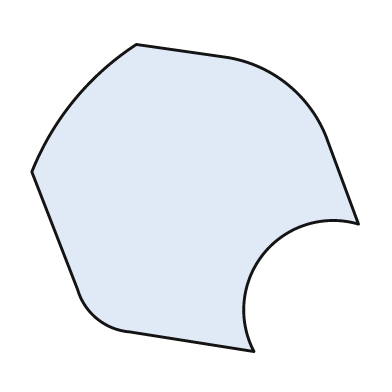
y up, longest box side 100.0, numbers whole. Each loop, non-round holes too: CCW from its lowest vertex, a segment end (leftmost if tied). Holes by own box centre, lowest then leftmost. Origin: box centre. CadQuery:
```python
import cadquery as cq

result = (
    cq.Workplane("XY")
    .moveTo(18.0, -47.0)
    .threePointArc((21.0, -17.0), (50.0, -8.0))
    .lineTo(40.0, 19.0)
    .threePointArc((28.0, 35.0), (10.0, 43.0))
    .lineTo(-18.0, 47.0)
    .threePointArc((-37.0, 30.0), (-50.0, 8.0))
    .lineTo(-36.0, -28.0)
    .threePointArc((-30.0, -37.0), (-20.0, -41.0))
    .close()
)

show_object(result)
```